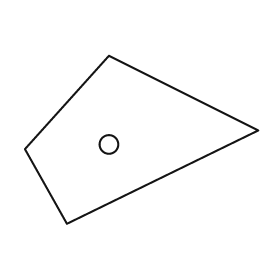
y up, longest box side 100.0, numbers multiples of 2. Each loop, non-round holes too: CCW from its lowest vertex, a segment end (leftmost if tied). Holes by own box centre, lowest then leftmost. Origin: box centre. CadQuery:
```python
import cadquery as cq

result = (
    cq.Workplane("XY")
    .moveTo(-32.0, -36.0)
    .lineTo(50.0, 4.0)
    .lineTo(-14.0, 36.0)
    .lineTo(-50.0, -4.0)
    .close()
    .moveTo(-14.0, -2.0)
    .circle(4.0)
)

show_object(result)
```